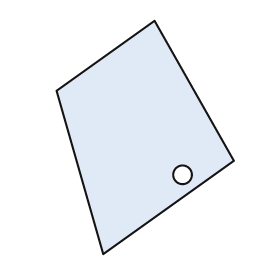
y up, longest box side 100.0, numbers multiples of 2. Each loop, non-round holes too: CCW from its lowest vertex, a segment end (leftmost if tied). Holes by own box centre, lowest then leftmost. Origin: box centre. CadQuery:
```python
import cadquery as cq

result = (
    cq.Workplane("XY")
    .moveTo(-18.0, -50.0)
    .lineTo(38.0, -10.0)
    .lineTo(4.0, 50.0)
    .lineTo(-38.0, 20.0)
    .close()
    .moveTo(16.0, -16.0)
    .circle(4.0)
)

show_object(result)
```